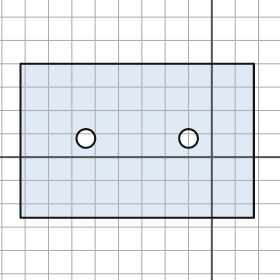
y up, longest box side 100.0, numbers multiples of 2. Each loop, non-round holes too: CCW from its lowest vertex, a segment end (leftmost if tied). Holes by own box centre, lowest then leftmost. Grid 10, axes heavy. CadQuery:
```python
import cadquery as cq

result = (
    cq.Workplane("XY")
    .moveTo(-82.0, -26.0)
    .lineTo(18.0, -26.0)
    .lineTo(18.0, 40.0)
    .lineTo(-82.0, 40.0)
    .close()
    .moveTo(-54.0, 8.0)
    .circle(4.0)
    .moveTo(-10.0, 8.0)
    .circle(4.0)
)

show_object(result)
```